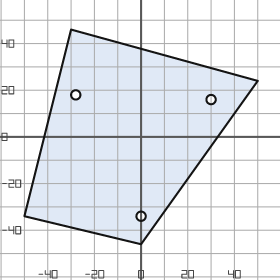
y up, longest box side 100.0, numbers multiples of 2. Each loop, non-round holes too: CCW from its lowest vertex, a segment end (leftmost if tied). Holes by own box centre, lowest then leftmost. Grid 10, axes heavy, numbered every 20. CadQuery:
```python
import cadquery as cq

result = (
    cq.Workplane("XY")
    .moveTo(0.0, -46.0)
    .lineTo(50.0, 24.0)
    .lineTo(-30.0, 46.0)
    .lineTo(-50.0, -34.0)
    .close()
    .moveTo(0.0, -34.0)
    .circle(2.0)
    .moveTo(30.0, 16.0)
    .circle(2.0)
    .moveTo(-28.0, 18.0)
    .circle(2.0)
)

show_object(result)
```